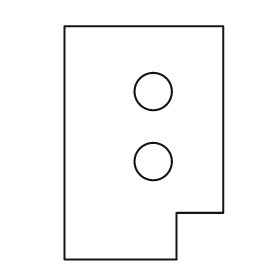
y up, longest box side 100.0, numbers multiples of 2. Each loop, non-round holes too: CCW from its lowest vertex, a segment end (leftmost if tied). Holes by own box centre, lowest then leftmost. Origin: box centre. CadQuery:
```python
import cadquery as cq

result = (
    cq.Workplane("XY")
    .moveTo(-34.0, -50.0)
    .lineTo(14.0, -50.0)
    .lineTo(14.0, -30.0)
    .lineTo(34.0, -30.0)
    .lineTo(34.0, 50.0)
    .lineTo(-34.0, 50.0)
    .close()
    .moveTo(4.0, -8.0)
    .circle(8.0)
    .moveTo(4.0, 22.0)
    .circle(8.0)
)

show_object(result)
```